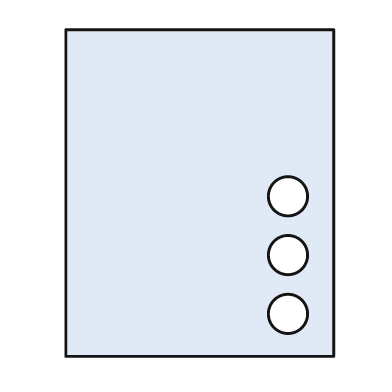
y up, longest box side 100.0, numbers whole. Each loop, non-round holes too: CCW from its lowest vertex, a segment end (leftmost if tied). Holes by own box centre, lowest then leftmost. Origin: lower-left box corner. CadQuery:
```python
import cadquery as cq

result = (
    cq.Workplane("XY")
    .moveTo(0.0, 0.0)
    .lineTo(82.0, 0.0)
    .lineTo(82.0, 100.0)
    .lineTo(0.0, 100.0)
    .close()
    .moveTo(68.0, 13.0)
    .circle(6.0)
    .moveTo(68.0, 31.0)
    .circle(6.0)
    .moveTo(68.0, 49.0)
    .circle(6.0)
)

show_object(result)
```